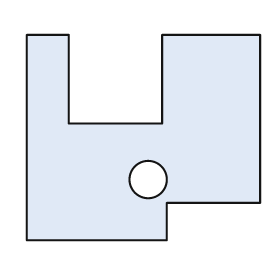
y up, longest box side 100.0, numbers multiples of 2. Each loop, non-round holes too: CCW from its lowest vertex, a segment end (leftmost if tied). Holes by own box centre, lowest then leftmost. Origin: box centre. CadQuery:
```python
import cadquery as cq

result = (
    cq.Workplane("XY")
    .moveTo(-50.0, -44.0)
    .lineTo(10.0, -44.0)
    .lineTo(10.0, -28.0)
    .lineTo(50.0, -28.0)
    .lineTo(50.0, 44.0)
    .lineTo(8.0, 44.0)
    .lineTo(8.0, 6.0)
    .lineTo(-32.0, 6.0)
    .lineTo(-32.0, 44.0)
    .lineTo(-50.0, 44.0)
    .close()
    .moveTo(2.0, -18.0)
    .circle(8.0)
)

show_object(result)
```